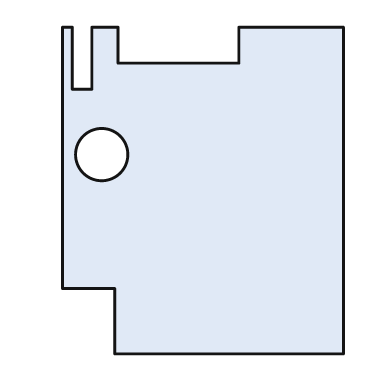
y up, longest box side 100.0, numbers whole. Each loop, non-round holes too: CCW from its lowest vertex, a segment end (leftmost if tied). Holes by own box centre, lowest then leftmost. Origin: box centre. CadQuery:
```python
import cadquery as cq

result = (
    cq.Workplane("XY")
    .moveTo(-27.0, -50.0)
    .lineTo(43.0, -50.0)
    .lineTo(43.0, 50.0)
    .lineTo(11.0, 50.0)
    .lineTo(11.0, 39.0)
    .lineTo(-26.0, 39.0)
    .lineTo(-26.0, 50.0)
    .lineTo(-34.0, 50.0)
    .lineTo(-34.0, 31.0)
    .lineTo(-40.0, 31.0)
    .lineTo(-40.0, 50.0)
    .lineTo(-43.0, 50.0)
    .lineTo(-43.0, -30.0)
    .lineTo(-27.0, -30.0)
    .close()
    .moveTo(-31.0, 11.0)
    .circle(8.0)
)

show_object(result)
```